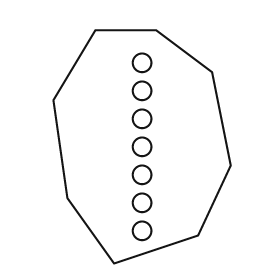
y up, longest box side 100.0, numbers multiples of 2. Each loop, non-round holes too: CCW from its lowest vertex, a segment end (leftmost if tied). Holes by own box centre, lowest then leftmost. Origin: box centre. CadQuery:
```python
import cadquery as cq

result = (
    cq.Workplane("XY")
    .moveTo(-12.0, -50.0)
    .lineTo(24.0, -38.0)
    .lineTo(38.0, -8.0)
    .lineTo(30.0, 32.0)
    .lineTo(6.0, 50.0)
    .lineTo(-20.0, 50.0)
    .lineTo(-38.0, 20.0)
    .lineTo(-32.0, -22.0)
    .close()
    .moveTo(0.0, -36.0)
    .circle(4.0)
    .moveTo(0.0, -24.0)
    .circle(4.0)
    .moveTo(0.0, -12.0)
    .circle(4.0)
    .moveTo(0.0, 0.0)
    .circle(4.0)
    .moveTo(0.0, 12.0)
    .circle(4.0)
    .moveTo(0.0, 24.0)
    .circle(4.0)
    .moveTo(0.0, 36.0)
    .circle(4.0)
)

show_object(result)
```